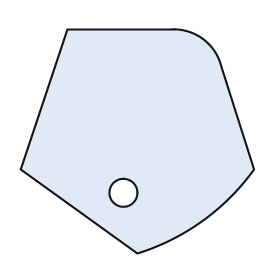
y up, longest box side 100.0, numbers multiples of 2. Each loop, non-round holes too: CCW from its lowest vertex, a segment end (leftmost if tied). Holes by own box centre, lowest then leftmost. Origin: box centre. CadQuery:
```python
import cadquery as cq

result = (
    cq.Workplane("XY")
    .moveTo(0.0, -48.0)
    .threePointArc((28.0, -34.0), (50.0, -12.0))
    .lineTo(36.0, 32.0)
    .threePointArc((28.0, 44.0), (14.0, 48.0))
    .lineTo(-30.0, 48.0)
    .lineTo(-50.0, -12.0)
    .close()
    .moveTo(-6.0, -22.0)
    .circle(6.0)
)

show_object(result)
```